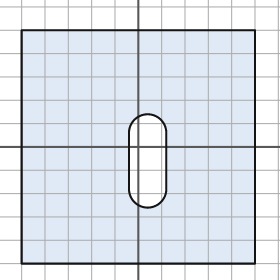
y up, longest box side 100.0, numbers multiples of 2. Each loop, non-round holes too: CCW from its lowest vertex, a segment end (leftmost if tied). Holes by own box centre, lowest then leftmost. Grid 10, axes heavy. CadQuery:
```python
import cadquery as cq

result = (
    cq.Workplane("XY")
    .moveTo(-50.0, -50.0)
    .lineTo(50.0, -50.0)
    .lineTo(50.0, 50.0)
    .lineTo(-50.0, 50.0)
    .close()
    .moveTo(-4.0, -18.0)
    .threePointArc((4.0, -26.0), (12.0, -18.0))
    .lineTo(12.0, 6.0)
    .threePointArc((4.0, 14.0), (-4.0, 6.0))
    .close()
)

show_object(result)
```